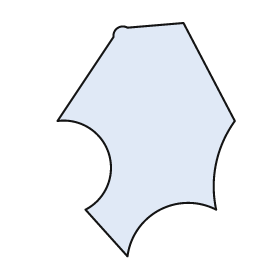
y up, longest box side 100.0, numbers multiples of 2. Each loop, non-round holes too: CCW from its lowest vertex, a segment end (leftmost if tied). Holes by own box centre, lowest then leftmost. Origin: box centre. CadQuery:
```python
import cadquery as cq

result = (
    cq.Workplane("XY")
    .moveTo(-8.0, -50.0)
    .threePointArc((6.0, -30.0), (30.0, -30.0))
    .threePointArc((30.0, -10.0), (38.0, 8.0))
    .lineTo(16.0, 50.0)
    .lineTo(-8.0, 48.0)
    .threePointArc((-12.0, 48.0), (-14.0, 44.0))
    .lineTo(-38.0, 8.0)
    .threePointArc((-16.0, -6.0), (-26.0, -30.0))
    .close()
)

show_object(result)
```